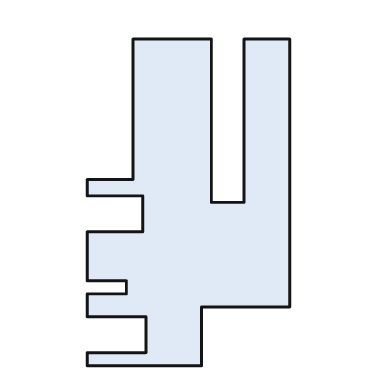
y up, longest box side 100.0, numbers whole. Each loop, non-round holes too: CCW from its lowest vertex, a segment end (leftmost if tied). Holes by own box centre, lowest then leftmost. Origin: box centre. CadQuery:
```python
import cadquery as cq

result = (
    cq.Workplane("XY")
    .moveTo(-31.0, -50.0)
    .lineTo(4.0, -50.0)
    .lineTo(4.0, -32.0)
    .lineTo(31.0, -32.0)
    .lineTo(31.0, 50.0)
    .lineTo(17.0, 50.0)
    .lineTo(17.0, 0.0)
    .lineTo(7.0, 0.0)
    .lineTo(7.0, 50.0)
    .lineTo(-17.0, 50.0)
    .lineTo(-17.0, 7.0)
    .lineTo(-31.0, 7.0)
    .lineTo(-31.0, 2.0)
    .lineTo(-14.0, 2.0)
    .lineTo(-14.0, -9.0)
    .lineTo(-31.0, -9.0)
    .lineTo(-31.0, -24.0)
    .lineTo(-19.0, -24.0)
    .lineTo(-19.0, -28.0)
    .lineTo(-31.0, -28.0)
    .lineTo(-31.0, -35.0)
    .lineTo(-13.0, -35.0)
    .lineTo(-13.0, -46.0)
    .lineTo(-31.0, -46.0)
    .close()
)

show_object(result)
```